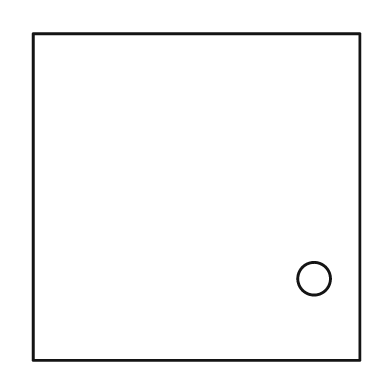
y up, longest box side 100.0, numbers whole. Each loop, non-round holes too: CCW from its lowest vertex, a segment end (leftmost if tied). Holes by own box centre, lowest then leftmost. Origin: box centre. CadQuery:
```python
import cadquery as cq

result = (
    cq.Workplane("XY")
    .moveTo(-50.0, -50.0)
    .lineTo(50.0, -50.0)
    .lineTo(50.0, 50.0)
    .lineTo(-50.0, 50.0)
    .close()
    .moveTo(36.0, -25.0)
    .circle(5.0)
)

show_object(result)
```